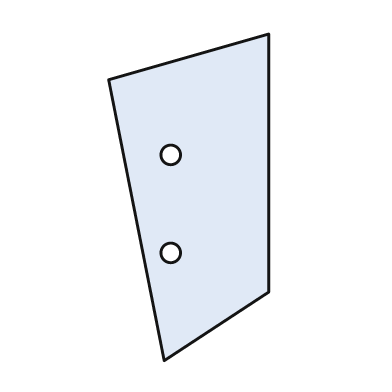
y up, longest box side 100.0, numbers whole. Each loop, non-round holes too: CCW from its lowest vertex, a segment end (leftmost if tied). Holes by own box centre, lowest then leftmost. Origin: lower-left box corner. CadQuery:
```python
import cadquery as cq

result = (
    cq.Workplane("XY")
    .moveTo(17.0, 0.0)
    .lineTo(49.0, 21.0)
    .lineTo(49.0, 100.0)
    .lineTo(0.0, 86.0)
    .close()
    .moveTo(19.0, 33.0)
    .circle(3.0)
    .moveTo(19.0, 63.0)
    .circle(3.0)
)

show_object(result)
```